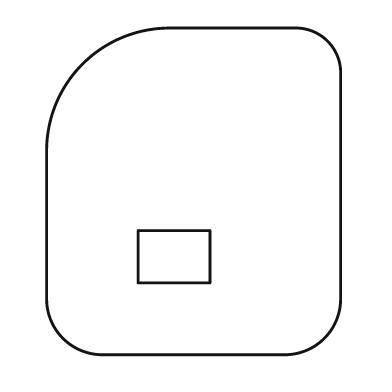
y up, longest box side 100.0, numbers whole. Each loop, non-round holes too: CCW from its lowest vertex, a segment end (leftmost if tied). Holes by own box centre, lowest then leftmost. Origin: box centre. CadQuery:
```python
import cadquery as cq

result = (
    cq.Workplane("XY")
    .moveTo(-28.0, -50.0)
    .lineTo(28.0, -50.0)
    .threePointArc((40.0, -45.0), (45.0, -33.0))
    .lineTo(45.0, 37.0)
    .threePointArc((41.0, 46.0), (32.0, 50.0))
    .lineTo(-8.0, 50.0)
    .threePointArc((-34.0, 39.0), (-45.0, 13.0))
    .lineTo(-45.0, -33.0)
    .threePointArc((-40.0, -45.0), (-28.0, -50.0))
    .close()
    .moveTo(-17.0, -28.0)
    .lineTo(5.0, -28.0)
    .lineTo(5.0, -12.0)
    .lineTo(-17.0, -12.0)
    .close()
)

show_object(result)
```